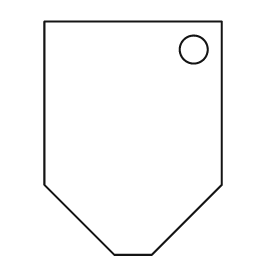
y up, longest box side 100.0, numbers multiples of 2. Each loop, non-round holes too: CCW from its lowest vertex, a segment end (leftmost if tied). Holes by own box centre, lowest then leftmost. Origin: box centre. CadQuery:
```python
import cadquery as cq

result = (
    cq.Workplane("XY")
    .moveTo(-8.0, -50.0)
    .lineTo(8.0, -50.0)
    .lineTo(38.0, -20.0)
    .lineTo(38.0, 50.0)
    .lineTo(-38.0, 50.0)
    .lineTo(-38.0, -20.0)
    .close()
    .moveTo(26.0, 38.0)
    .circle(6.0)
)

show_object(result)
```